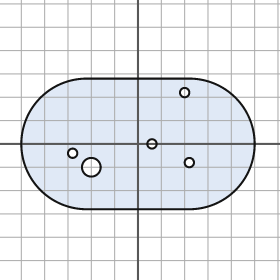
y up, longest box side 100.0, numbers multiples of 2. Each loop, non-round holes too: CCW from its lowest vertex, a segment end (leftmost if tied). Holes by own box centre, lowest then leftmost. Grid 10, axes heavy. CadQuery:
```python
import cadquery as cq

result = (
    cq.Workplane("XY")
    .moveTo(-22.0, -28.0)
    .lineTo(22.0, -28.0)
    .threePointArc((50.0, 0.0), (22.0, 28.0))
    .lineTo(-22.0, 28.0)
    .threePointArc((-50.0, 0.0), (-22.0, -28.0))
    .close()
    .moveTo(-20.0, -10.0)
    .circle(4.0)
    .moveTo(22.0, -8.0)
    .circle(2.0)
    .moveTo(-28.0, -4.0)
    .circle(2.0)
    .moveTo(6.0, 0.0)
    .circle(2.0)
    .moveTo(20.0, 22.0)
    .circle(2.0)
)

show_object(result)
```